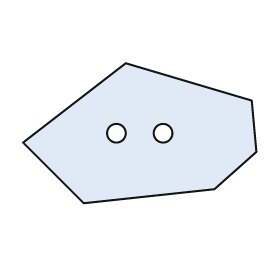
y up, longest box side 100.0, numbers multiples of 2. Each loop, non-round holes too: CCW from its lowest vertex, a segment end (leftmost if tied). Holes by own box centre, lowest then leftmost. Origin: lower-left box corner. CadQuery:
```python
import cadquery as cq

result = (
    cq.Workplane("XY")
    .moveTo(26.0, 0.0)
    .lineTo(82.0, 6.0)
    .lineTo(100.0, 22.0)
    .lineTo(98.0, 44.0)
    .lineTo(44.0, 60.0)
    .lineTo(0.0, 26.0)
    .close()
    .moveTo(40.0, 30.0)
    .circle(4.0)
    .moveTo(60.0, 30.0)
    .circle(4.0)
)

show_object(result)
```